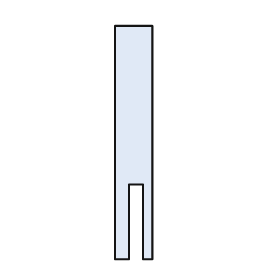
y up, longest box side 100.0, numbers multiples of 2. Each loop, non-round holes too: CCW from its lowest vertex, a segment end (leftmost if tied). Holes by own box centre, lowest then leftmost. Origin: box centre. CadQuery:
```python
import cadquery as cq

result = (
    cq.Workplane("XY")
    .moveTo(-8.0, -50.0)
    .lineTo(-2.0, -50.0)
    .lineTo(-2.0, -18.0)
    .lineTo(4.0, -18.0)
    .lineTo(4.0, -50.0)
    .lineTo(8.0, -50.0)
    .lineTo(8.0, 50.0)
    .lineTo(-8.0, 50.0)
    .close()
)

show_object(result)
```